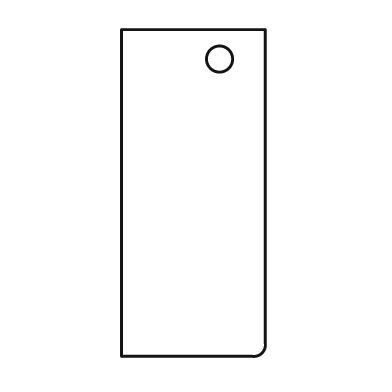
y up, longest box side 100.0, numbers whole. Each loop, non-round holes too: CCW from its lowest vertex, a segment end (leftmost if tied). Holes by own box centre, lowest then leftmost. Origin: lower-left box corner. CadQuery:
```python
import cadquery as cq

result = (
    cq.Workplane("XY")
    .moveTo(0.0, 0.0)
    .lineTo(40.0, 0.0)
    .threePointArc((43.0, 1.0), (44.0, 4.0))
    .lineTo(44.0, 100.0)
    .lineTo(0.0, 100.0)
    .close()
    .moveTo(30.0, 91.0)
    .circle(4.0)
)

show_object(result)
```